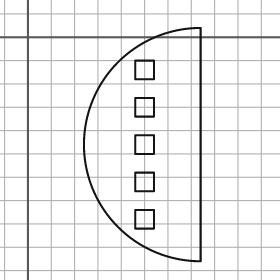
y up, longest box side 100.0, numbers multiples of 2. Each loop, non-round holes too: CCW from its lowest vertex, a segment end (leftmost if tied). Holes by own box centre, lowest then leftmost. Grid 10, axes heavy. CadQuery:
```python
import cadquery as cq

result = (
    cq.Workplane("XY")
    .moveTo(74.0, -96.0)
    .lineTo(74.0, 4.0)
    .threePointArc((24.0, -46.0), (74.0, -96.0))
    .close()
    .moveTo(46.0, -82.0)
    .lineTo(54.0, -82.0)
    .lineTo(54.0, -74.0)
    .lineTo(46.0, -74.0)
    .close()
    .moveTo(46.0, -66.0)
    .lineTo(54.0, -66.0)
    .lineTo(54.0, -58.0)
    .lineTo(46.0, -58.0)
    .close()
    .moveTo(46.0, -50.0)
    .lineTo(54.0, -50.0)
    .lineTo(54.0, -42.0)
    .lineTo(46.0, -42.0)
    .close()
    .moveTo(46.0, -34.0)
    .lineTo(54.0, -34.0)
    .lineTo(54.0, -26.0)
    .lineTo(46.0, -26.0)
    .close()
    .moveTo(46.0, -18.0)
    .lineTo(54.0, -18.0)
    .lineTo(54.0, -10.0)
    .lineTo(46.0, -10.0)
    .close()
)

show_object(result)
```